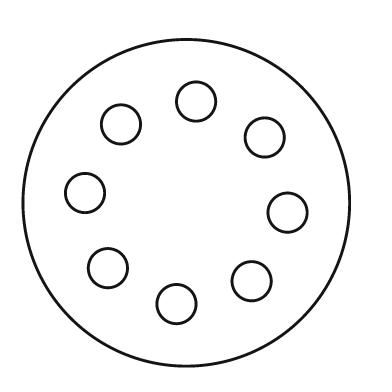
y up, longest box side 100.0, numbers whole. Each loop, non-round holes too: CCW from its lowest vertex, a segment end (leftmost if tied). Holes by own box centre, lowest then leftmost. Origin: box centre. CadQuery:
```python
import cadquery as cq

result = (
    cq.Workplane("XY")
    .moveTo(0.0, 0.0)
    .circle(50.0)
    .moveTo(-3.0, -31.0)
    .circle(6.0)
    .moveTo(20.0, -24.0)
    .circle(6.0)
    .moveTo(-24.0, -20.0)
    .circle(6.0)
    .moveTo(31.0, -3.0)
    .circle(6.0)
    .moveTo(-31.0, 3.0)
    .circle(6.0)
    .moveTo(24.0, 20.0)
    .circle(6.0)
    .moveTo(-20.0, 24.0)
    .circle(6.0)
    .moveTo(3.0, 31.0)
    .circle(6.0)
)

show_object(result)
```